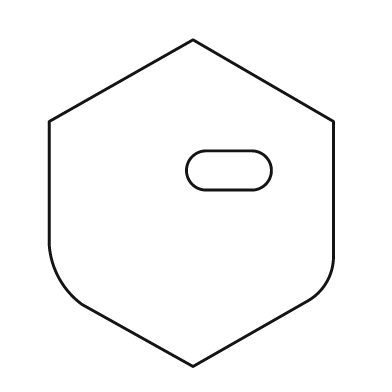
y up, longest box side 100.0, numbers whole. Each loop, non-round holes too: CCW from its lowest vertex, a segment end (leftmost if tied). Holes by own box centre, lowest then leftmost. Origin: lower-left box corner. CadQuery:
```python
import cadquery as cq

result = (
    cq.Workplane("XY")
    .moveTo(44.0, 0.0)
    .lineTo(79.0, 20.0)
    .threePointArc((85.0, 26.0), (87.0, 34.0))
    .lineTo(87.0, 75.0)
    .lineTo(44.0, 100.0)
    .lineTo(0.0, 75.0)
    .lineTo(0.0, 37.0)
    .threePointArc((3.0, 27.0), (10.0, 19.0))
    .close()
    .moveTo(48.0, 54.0)
    .lineTo(62.0, 54.0)
    .threePointArc((68.0, 60.0), (62.0, 66.0))
    .lineTo(48.0, 66.0)
    .threePointArc((42.0, 60.0), (48.0, 54.0))
    .close()
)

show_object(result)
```